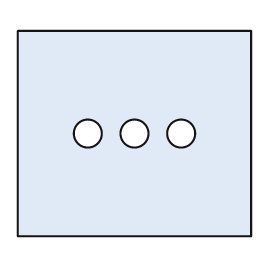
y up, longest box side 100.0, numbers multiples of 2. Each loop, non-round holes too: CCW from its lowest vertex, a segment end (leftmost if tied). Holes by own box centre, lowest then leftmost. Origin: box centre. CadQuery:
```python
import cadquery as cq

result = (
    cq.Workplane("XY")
    .moveTo(-50.0, -44.0)
    .lineTo(50.0, -44.0)
    .lineTo(50.0, 44.0)
    .lineTo(-50.0, 44.0)
    .close()
    .moveTo(-20.0, 0.0)
    .circle(6.0)
    .moveTo(0.0, 0.0)
    .circle(6.0)
    .moveTo(20.0, 0.0)
    .circle(6.0)
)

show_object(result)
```